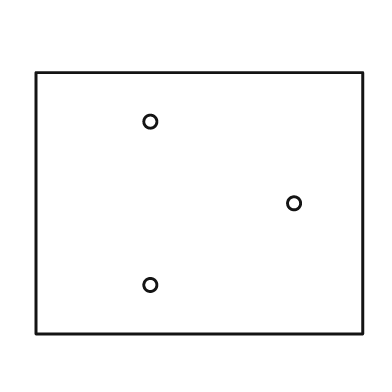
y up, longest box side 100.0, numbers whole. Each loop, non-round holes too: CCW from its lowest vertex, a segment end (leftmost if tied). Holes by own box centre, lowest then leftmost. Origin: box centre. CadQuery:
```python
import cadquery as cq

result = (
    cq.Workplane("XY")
    .moveTo(-50.0, -40.0)
    .lineTo(50.0, -40.0)
    .lineTo(50.0, 40.0)
    .lineTo(-50.0, 40.0)
    .close()
    .moveTo(-15.0, -25.0)
    .circle(2.0)
    .moveTo(29.0, 0.0)
    .circle(2.0)
    .moveTo(-15.0, 25.0)
    .circle(2.0)
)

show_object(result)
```